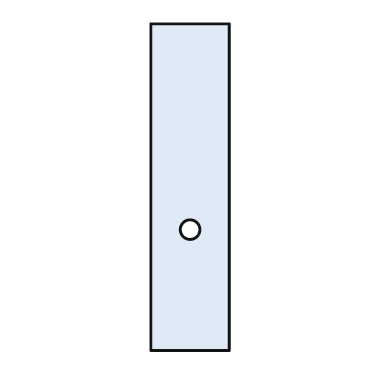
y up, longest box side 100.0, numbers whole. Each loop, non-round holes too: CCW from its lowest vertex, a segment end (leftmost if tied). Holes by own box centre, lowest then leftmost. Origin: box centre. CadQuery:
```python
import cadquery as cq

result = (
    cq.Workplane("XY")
    .moveTo(-12.0, -50.0)
    .lineTo(12.0, -50.0)
    .lineTo(12.0, 50.0)
    .lineTo(-12.0, 50.0)
    .close()
    .moveTo(0.0, -13.0)
    .circle(3.0)
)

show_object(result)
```